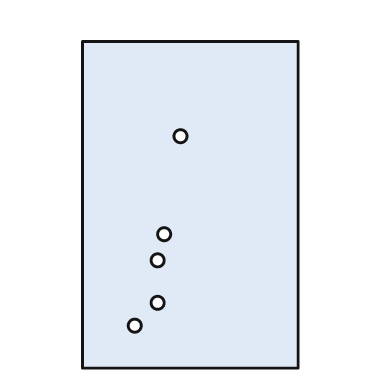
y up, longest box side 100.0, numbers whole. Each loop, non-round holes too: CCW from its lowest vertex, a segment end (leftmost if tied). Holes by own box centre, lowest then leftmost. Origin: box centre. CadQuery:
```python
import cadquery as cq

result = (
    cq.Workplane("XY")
    .moveTo(-33.0, -50.0)
    .lineTo(33.0, -50.0)
    .lineTo(33.0, 50.0)
    .lineTo(-33.0, 50.0)
    .close()
    .moveTo(-17.0, -37.0)
    .circle(2.0)
    .moveTo(-10.0, -30.0)
    .circle(2.0)
    .moveTo(-10.0, -17.0)
    .circle(2.0)
    .moveTo(-8.0, -9.0)
    .circle(2.0)
    .moveTo(-3.0, 21.0)
    .circle(2.0)
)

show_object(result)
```